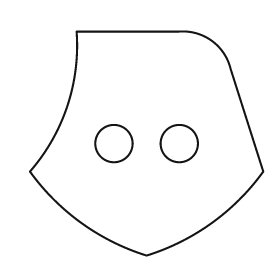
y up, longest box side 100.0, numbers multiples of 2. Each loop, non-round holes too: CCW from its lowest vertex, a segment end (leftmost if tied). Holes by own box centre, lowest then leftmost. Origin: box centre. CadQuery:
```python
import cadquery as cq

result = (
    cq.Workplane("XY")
    .moveTo(0.0, -48.0)
    .threePointArc((28.0, -34.0), (50.0, -12.0))
    .lineTo(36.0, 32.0)
    .threePointArc((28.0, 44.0), (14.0, 48.0))
    .lineTo(-30.0, 48.0)
    .threePointArc((-34.0, 16.0), (-50.0, -12.0))
    .threePointArc((-28.0, -34.0), (0.0, -48.0))
    .close()
    .moveTo(-14.0, 0.0)
    .circle(8.0)
    .moveTo(14.0, 0.0)
    .circle(8.0)
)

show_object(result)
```